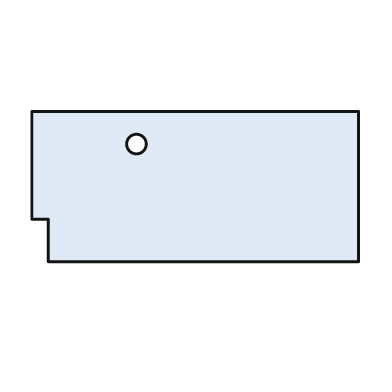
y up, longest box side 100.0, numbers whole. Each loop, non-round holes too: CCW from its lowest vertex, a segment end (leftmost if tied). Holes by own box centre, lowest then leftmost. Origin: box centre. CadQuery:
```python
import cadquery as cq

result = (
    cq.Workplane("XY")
    .moveTo(-45.0, -23.0)
    .lineTo(50.0, -23.0)
    .lineTo(50.0, 23.0)
    .lineTo(-50.0, 23.0)
    .lineTo(-50.0, -10.0)
    .lineTo(-45.0, -10.0)
    .close()
    .moveTo(-18.0, 13.0)
    .circle(3.0)
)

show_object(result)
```